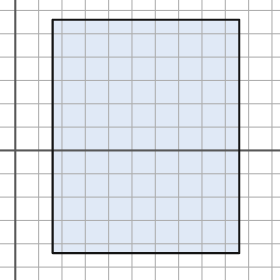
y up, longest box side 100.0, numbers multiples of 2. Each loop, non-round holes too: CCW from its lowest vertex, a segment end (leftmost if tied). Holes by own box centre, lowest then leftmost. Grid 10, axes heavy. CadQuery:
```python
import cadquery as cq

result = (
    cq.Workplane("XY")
    .moveTo(16.0, -44.0)
    .lineTo(96.0, -44.0)
    .lineTo(96.0, 56.0)
    .lineTo(16.0, 56.0)
    .close()
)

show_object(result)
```